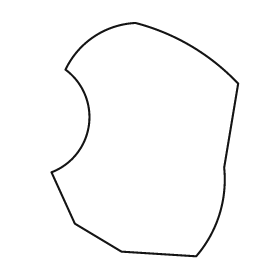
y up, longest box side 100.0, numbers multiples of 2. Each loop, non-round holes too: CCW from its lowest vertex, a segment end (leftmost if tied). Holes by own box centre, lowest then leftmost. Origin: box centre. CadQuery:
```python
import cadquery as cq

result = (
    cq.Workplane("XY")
    .moveTo(22.0, -50.0)
    .threePointArc((32.0, -32.0), (34.0, -12.0))
    .lineTo(40.0, 24.0)
    .threePointArc((20.0, 40.0), (-4.0, 50.0))
    .threePointArc((-22.0, 44.0), (-34.0, 30.0))
    .threePointArc((-24.0, 6.0), (-40.0, -14.0))
    .lineTo(-30.0, -36.0)
    .lineTo(-10.0, -48.0)
    .close()
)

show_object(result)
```